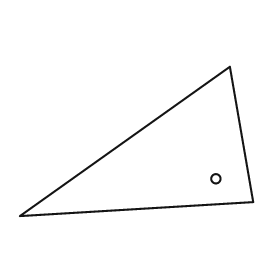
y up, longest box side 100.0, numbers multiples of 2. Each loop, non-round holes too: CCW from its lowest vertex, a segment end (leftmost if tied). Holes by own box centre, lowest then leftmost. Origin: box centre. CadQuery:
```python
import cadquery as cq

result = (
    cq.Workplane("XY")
    .moveTo(-50.0, -32.0)
    .lineTo(50.0, -26.0)
    .lineTo(40.0, 32.0)
    .close()
    .moveTo(34.0, -16.0)
    .circle(2.0)
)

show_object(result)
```